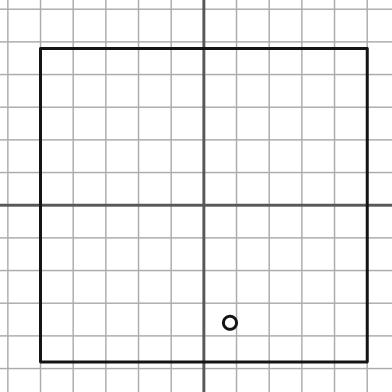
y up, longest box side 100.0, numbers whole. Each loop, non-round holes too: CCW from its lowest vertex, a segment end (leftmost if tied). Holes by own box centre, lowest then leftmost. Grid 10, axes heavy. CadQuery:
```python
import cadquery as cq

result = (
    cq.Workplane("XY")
    .moveTo(-50.0, -48.0)
    .lineTo(50.0, -48.0)
    .lineTo(50.0, 48.0)
    .lineTo(-50.0, 48.0)
    .close()
    .moveTo(8.0, -36.0)
    .circle(2.0)
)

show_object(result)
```